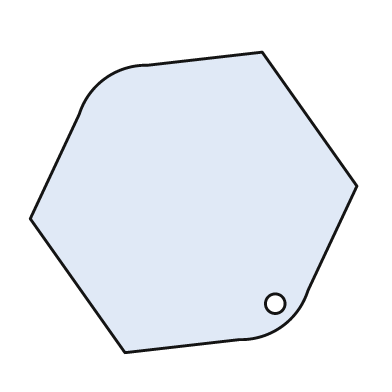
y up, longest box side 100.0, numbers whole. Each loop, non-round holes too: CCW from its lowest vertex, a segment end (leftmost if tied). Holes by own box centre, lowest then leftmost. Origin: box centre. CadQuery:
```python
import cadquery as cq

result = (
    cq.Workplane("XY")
    .moveTo(-21.0, -46.0)
    .lineTo(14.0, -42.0)
    .threePointArc((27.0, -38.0), (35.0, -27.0))
    .lineTo(50.0, 5.0)
    .lineTo(21.0, 46.0)
    .lineTo(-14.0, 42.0)
    .threePointArc((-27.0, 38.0), (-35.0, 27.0))
    .lineTo(-50.0, -5.0)
    .close()
    .moveTo(25.0, -31.0)
    .circle(3.0)
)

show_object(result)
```